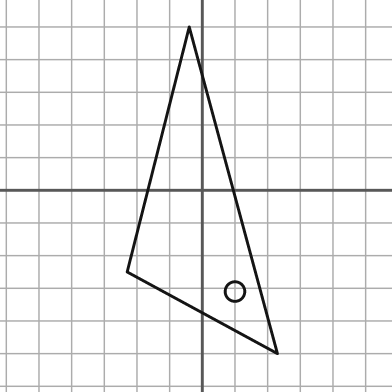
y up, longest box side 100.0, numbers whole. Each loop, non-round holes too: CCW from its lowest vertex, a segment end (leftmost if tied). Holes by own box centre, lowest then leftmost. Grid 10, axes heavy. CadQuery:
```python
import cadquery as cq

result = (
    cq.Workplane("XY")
    .moveTo(23.0, -50.0)
    .lineTo(-4.0, 50.0)
    .lineTo(-23.0, -25.0)
    .close()
    .moveTo(10.0, -31.0)
    .circle(3.0)
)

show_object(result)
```